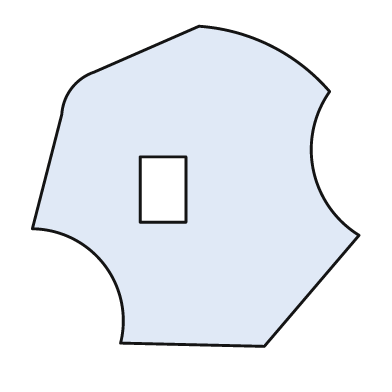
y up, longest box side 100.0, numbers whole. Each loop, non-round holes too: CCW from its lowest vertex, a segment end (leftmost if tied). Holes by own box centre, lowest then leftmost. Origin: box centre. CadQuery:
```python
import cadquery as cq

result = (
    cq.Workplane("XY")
    .moveTo(21.0, -49.0)
    .lineTo(50.0, -15.0)
    .threePointArc((36.0, 5.0), (41.0, 29.0))
    .threePointArc((23.0, 43.0), (1.0, 49.0))
    .lineTo(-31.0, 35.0)
    .threePointArc((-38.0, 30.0), (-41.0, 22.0))
    .lineTo(-50.0, -13.0)
    .threePointArc((-28.0, -24.0), (-23.0, -48.0))
    .close()
    .moveTo(-17.0, -11.0)
    .lineTo(-3.0, -11.0)
    .lineTo(-3.0, 9.0)
    .lineTo(-17.0, 9.0)
    .close()
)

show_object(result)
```